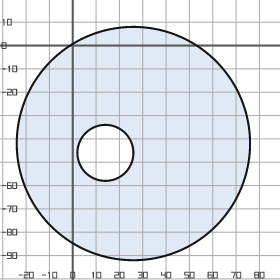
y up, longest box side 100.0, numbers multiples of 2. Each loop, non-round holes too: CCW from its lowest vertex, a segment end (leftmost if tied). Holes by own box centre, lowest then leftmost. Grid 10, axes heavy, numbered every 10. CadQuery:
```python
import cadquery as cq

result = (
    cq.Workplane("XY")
    .moveTo(26.0, -42.0)
    .circle(50.0)
    .moveTo(14.0, -46.0)
    .circle(12.0)
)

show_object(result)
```